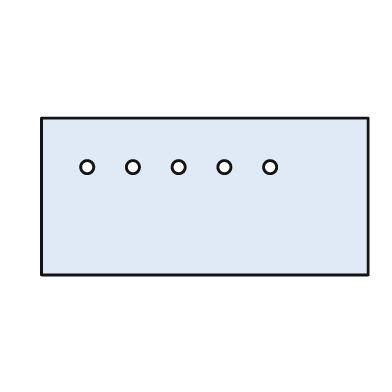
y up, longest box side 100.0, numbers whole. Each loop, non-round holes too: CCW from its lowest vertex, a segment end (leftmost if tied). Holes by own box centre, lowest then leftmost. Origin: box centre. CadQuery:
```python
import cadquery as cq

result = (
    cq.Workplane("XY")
    .moveTo(-50.0, -24.0)
    .lineTo(50.0, -24.0)
    .lineTo(50.0, 24.0)
    .lineTo(-50.0, 24.0)
    .close()
    .moveTo(-36.0, 9.0)
    .circle(2.0)
    .moveTo(-22.0, 9.0)
    .circle(2.0)
    .moveTo(-8.0, 9.0)
    .circle(2.0)
    .moveTo(6.0, 9.0)
    .circle(2.0)
    .moveTo(20.0, 9.0)
    .circle(2.0)
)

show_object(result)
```